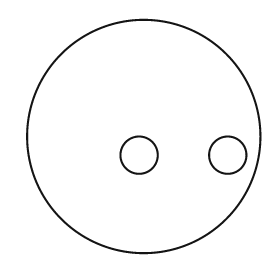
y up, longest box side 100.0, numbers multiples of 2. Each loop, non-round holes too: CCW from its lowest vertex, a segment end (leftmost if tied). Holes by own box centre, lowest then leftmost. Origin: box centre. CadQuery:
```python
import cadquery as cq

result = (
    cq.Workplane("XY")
    .moveTo(0.0, 0.0)
    .circle(50.0)
    .moveTo(-2.0, -8.0)
    .circle(8.0)
    .moveTo(36.0, -8.0)
    .circle(8.0)
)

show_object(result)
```